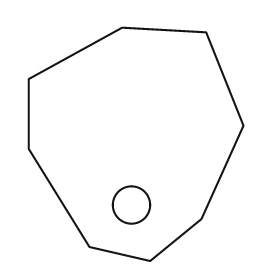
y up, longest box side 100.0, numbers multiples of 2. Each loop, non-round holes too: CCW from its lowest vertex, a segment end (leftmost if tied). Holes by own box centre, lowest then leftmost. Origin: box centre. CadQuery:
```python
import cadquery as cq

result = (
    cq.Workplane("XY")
    .moveTo(6.0, -50.0)
    .lineTo(28.0, -32.0)
    .lineTo(46.0, 8.0)
    .lineTo(30.0, 48.0)
    .lineTo(-6.0, 50.0)
    .lineTo(-46.0, 28.0)
    .lineTo(-46.0, -2.0)
    .lineTo(-20.0, -44.0)
    .close()
    .moveTo(-2.0, -26.0)
    .circle(8.0)
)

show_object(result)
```